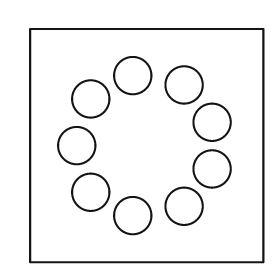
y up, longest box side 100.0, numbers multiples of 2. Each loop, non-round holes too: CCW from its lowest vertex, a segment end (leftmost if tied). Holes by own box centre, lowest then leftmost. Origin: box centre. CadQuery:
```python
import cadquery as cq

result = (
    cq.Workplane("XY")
    .moveTo(-50.0, -50.0)
    .lineTo(50.0, -50.0)
    .lineTo(50.0, 50.0)
    .lineTo(-50.0, 50.0)
    .close()
    .moveTo(-6.0, -30.0)
    .circle(8.0)
    .moveTo(16.0, -26.0)
    .circle(8.0)
    .moveTo(-24.0, -20.0)
    .circle(8.0)
    .moveTo(28.0, -10.0)
    .circle(8.0)
    .moveTo(-30.0, 0.0)
    .circle(8.0)
    .moveTo(28.0, 10.0)
    .circle(8.0)
    .moveTo(-24.0, 20.0)
    .circle(8.0)
    .moveTo(16.0, 26.0)
    .circle(8.0)
    .moveTo(-6.0, 30.0)
    .circle(8.0)
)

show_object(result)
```